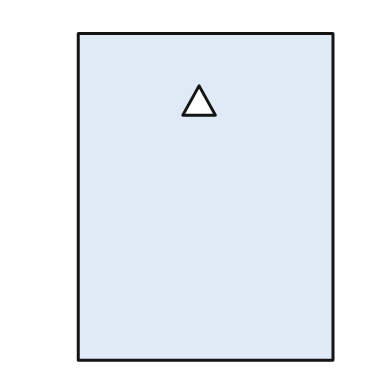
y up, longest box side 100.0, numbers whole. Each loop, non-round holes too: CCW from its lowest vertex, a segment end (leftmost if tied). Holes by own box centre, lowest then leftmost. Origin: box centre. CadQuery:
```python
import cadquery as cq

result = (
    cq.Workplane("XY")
    .moveTo(-39.0, -50.0)
    .lineTo(39.0, -50.0)
    .lineTo(39.0, 50.0)
    .lineTo(-39.0, 50.0)
    .close()
    .moveTo(-7.0, 25.0)
    .lineTo(3.0, 25.0)
    .lineTo(-2.0, 34.0)
    .close()
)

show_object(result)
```